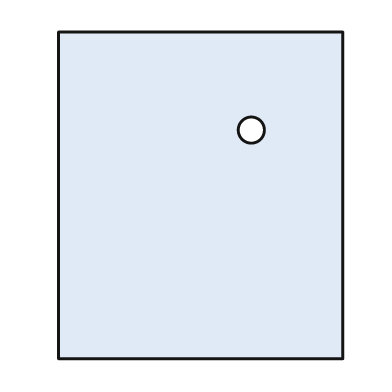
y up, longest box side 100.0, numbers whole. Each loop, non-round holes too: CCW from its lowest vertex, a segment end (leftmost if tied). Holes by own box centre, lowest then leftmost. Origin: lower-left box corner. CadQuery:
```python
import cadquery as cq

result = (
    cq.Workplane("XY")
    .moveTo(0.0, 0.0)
    .lineTo(87.0, 0.0)
    .lineTo(87.0, 100.0)
    .lineTo(0.0, 100.0)
    .close()
    .moveTo(59.0, 70.0)
    .circle(4.0)
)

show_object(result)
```